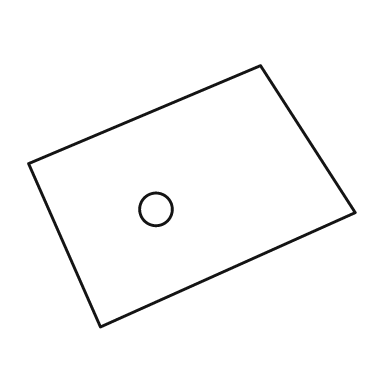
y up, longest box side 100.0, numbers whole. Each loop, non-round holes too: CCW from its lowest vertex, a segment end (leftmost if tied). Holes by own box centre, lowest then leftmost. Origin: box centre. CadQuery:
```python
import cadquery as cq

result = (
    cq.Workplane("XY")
    .moveTo(-28.0, -40.0)
    .lineTo(50.0, -5.0)
    .lineTo(21.0, 40.0)
    .lineTo(-50.0, 10.0)
    .close()
    .moveTo(-11.0, -4.0)
    .circle(5.0)
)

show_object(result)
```